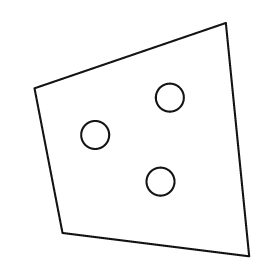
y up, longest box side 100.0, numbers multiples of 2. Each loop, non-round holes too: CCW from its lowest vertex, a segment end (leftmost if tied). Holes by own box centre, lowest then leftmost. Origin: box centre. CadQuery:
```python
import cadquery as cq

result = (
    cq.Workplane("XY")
    .moveTo(46.0, -50.0)
    .lineTo(36.0, 50.0)
    .lineTo(-46.0, 22.0)
    .lineTo(-34.0, -40.0)
    .close()
    .moveTo(8.0, -18.0)
    .circle(6.0)
    .moveTo(-20.0, 2.0)
    .circle(6.0)
    .moveTo(12.0, 18.0)
    .circle(6.0)
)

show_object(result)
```